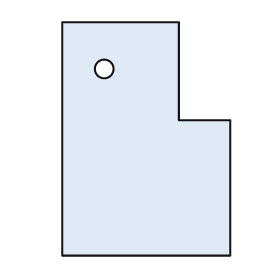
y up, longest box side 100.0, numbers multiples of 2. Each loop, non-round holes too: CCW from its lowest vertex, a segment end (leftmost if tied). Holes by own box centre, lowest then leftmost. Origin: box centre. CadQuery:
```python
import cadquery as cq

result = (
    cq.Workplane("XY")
    .moveTo(-36.0, -50.0)
    .lineTo(36.0, -50.0)
    .lineTo(36.0, 8.0)
    .lineTo(14.0, 8.0)
    .lineTo(14.0, 50.0)
    .lineTo(-36.0, 50.0)
    .close()
    .moveTo(-18.0, 30.0)
    .circle(4.0)
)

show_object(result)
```